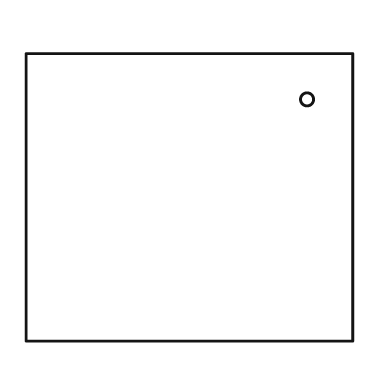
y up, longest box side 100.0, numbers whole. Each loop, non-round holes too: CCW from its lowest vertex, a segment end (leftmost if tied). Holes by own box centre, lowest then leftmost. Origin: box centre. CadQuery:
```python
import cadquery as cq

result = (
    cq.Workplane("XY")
    .moveTo(-50.0, -44.0)
    .lineTo(50.0, -44.0)
    .lineTo(50.0, 44.0)
    .lineTo(-50.0, 44.0)
    .close()
    .moveTo(36.0, 30.0)
    .circle(2.0)
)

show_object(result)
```